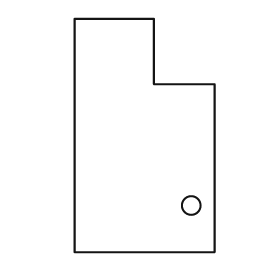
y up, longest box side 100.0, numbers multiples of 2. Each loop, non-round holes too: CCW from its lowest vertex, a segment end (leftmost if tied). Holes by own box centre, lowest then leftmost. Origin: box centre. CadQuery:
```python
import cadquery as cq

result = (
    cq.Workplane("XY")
    .moveTo(-30.0, -50.0)
    .lineTo(30.0, -50.0)
    .lineTo(30.0, 22.0)
    .lineTo(4.0, 22.0)
    .lineTo(4.0, 50.0)
    .lineTo(-30.0, 50.0)
    .close()
    .moveTo(20.0, -30.0)
    .circle(4.0)
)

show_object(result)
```